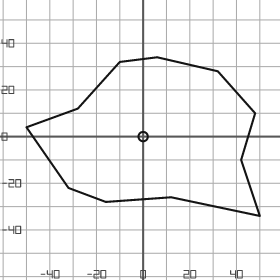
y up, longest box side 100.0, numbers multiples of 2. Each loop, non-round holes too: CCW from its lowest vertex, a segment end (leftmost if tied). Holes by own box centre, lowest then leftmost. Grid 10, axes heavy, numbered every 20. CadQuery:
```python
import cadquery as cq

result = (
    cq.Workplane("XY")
    .moveTo(50.0, -34.0)
    .lineTo(42.0, -10.0)
    .lineTo(48.0, 10.0)
    .lineTo(32.0, 28.0)
    .lineTo(6.0, 34.0)
    .lineTo(-10.0, 32.0)
    .lineTo(-28.0, 12.0)
    .lineTo(-50.0, 4.0)
    .lineTo(-32.0, -22.0)
    .lineTo(-16.0, -28.0)
    .lineTo(12.0, -26.0)
    .close()
    .moveTo(0.0, 0.0)
    .circle(2.0)
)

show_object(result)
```